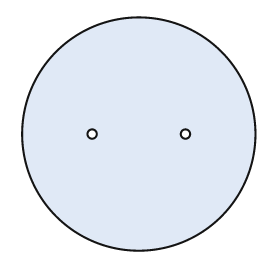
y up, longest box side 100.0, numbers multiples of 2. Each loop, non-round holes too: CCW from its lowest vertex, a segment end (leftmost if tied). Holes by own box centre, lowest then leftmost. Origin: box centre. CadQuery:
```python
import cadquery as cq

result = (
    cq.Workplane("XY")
    .moveTo(0.0, 0.0)
    .circle(50.0)
    .moveTo(-20.0, 0.0)
    .circle(2.0)
    .moveTo(20.0, 0.0)
    .circle(2.0)
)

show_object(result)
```